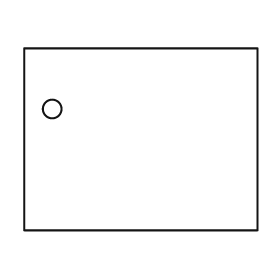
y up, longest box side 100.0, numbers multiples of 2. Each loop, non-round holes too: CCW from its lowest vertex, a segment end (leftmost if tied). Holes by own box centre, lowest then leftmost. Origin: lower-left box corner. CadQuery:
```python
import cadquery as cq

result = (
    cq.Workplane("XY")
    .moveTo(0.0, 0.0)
    .lineTo(100.0, 0.0)
    .lineTo(100.0, 78.0)
    .lineTo(0.0, 78.0)
    .close()
    .moveTo(12.0, 52.0)
    .circle(4.0)
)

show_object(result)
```